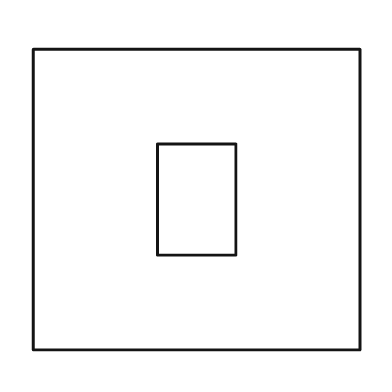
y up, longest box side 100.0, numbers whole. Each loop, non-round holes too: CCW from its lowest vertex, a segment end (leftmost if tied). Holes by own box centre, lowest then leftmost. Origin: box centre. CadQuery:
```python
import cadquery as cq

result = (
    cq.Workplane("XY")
    .moveTo(-50.0, -46.0)
    .lineTo(50.0, -46.0)
    .lineTo(50.0, 46.0)
    .lineTo(-50.0, 46.0)
    .close()
    .moveTo(-12.0, -17.0)
    .lineTo(12.0, -17.0)
    .lineTo(12.0, 17.0)
    .lineTo(-12.0, 17.0)
    .close()
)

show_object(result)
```